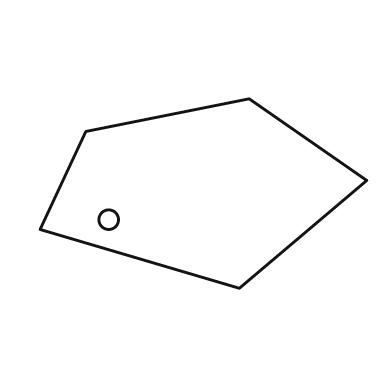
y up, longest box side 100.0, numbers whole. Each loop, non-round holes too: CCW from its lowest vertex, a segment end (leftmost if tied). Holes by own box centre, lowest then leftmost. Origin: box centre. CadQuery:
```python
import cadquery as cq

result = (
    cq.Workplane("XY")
    .moveTo(11.0, -29.0)
    .lineTo(50.0, 4.0)
    .lineTo(14.0, 29.0)
    .lineTo(-36.0, 19.0)
    .lineTo(-50.0, -11.0)
    .close()
    .moveTo(-29.0, -8.0)
    .circle(3.0)
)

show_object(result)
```